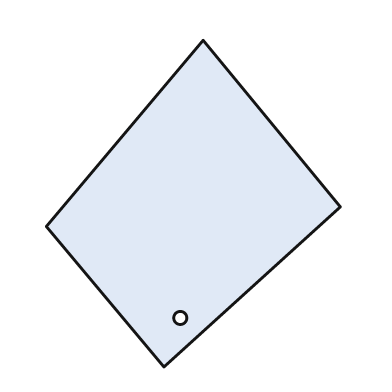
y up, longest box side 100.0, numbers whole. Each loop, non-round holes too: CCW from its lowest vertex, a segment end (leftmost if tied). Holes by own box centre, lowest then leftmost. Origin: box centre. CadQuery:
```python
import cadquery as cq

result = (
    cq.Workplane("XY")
    .moveTo(-9.0, -50.0)
    .lineTo(45.0, -1.0)
    .lineTo(3.0, 50.0)
    .lineTo(-45.0, -7.0)
    .close()
    .moveTo(-4.0, -35.0)
    .circle(2.0)
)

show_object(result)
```